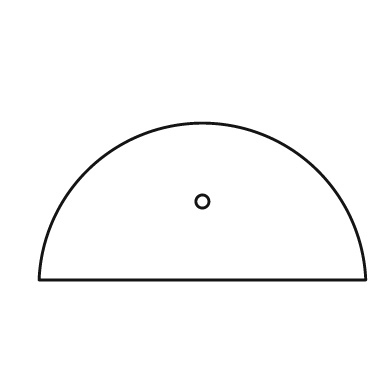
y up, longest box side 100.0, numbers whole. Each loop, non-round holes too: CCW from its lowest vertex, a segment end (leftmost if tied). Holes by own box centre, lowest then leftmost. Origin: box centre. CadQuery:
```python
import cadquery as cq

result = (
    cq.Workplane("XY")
    .moveTo(-50.0, -24.0)
    .lineTo(50.0, -24.0)
    .threePointArc((0.0, 24.0), (-50.0, -24.0))
    .close()
    .moveTo(0.0, 0.0)
    .circle(2.0)
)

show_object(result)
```